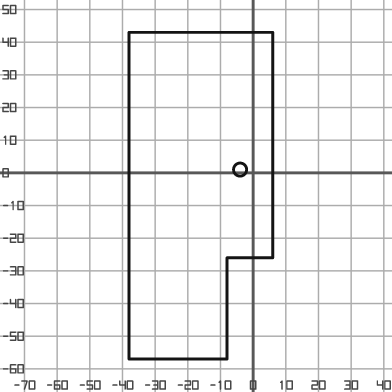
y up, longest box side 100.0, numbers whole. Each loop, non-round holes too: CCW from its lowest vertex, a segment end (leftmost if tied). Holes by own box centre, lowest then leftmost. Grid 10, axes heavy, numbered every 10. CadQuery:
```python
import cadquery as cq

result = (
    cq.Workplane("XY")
    .moveTo(-38.0, -57.0)
    .lineTo(-8.0, -57.0)
    .lineTo(-8.0, -26.0)
    .lineTo(6.0, -26.0)
    .lineTo(6.0, 43.0)
    .lineTo(-38.0, 43.0)
    .close()
    .moveTo(-4.0, 1.0)
    .circle(2.0)
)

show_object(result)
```